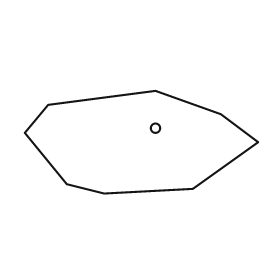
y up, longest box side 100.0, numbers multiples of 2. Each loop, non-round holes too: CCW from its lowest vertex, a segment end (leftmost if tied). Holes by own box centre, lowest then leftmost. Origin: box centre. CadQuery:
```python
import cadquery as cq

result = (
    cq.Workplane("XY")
    .moveTo(-16.0, -22.0)
    .lineTo(22.0, -20.0)
    .lineTo(50.0, 0.0)
    .lineTo(34.0, 12.0)
    .lineTo(6.0, 22.0)
    .lineTo(-40.0, 16.0)
    .lineTo(-50.0, 4.0)
    .lineTo(-32.0, -18.0)
    .close()
    .moveTo(6.0, 6.0)
    .circle(2.0)
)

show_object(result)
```